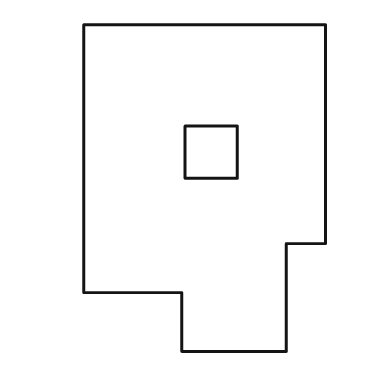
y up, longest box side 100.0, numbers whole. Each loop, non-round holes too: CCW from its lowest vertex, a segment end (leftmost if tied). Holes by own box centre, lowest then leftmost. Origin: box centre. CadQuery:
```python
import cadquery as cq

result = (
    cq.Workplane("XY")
    .moveTo(-7.0, -50.0)
    .lineTo(25.0, -50.0)
    .lineTo(25.0, -17.0)
    .lineTo(37.0, -17.0)
    .lineTo(37.0, 50.0)
    .lineTo(-37.0, 50.0)
    .lineTo(-37.0, -32.0)
    .lineTo(-7.0, -32.0)
    .close()
    .moveTo(-6.0, 3.0)
    .lineTo(10.0, 3.0)
    .lineTo(10.0, 19.0)
    .lineTo(-6.0, 19.0)
    .close()
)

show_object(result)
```